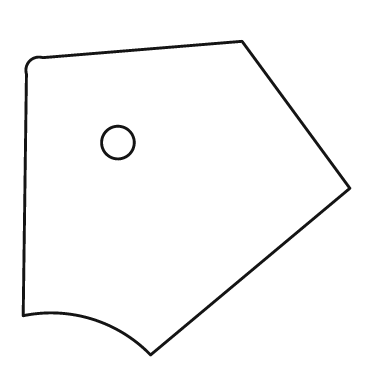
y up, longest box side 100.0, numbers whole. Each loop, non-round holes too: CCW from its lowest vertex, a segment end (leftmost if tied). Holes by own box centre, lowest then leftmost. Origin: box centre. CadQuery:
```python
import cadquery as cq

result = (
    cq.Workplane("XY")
    .moveTo(-11.0, -48.0)
    .lineTo(50.0, 3.0)
    .lineTo(17.0, 48.0)
    .lineTo(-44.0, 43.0)
    .threePointArc((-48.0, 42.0), (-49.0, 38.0))
    .lineTo(-50.0, -36.0)
    .threePointArc((-29.0, -37.0), (-11.0, -48.0))
    .close()
    .moveTo(-21.0, 17.0)
    .circle(5.0)
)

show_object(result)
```